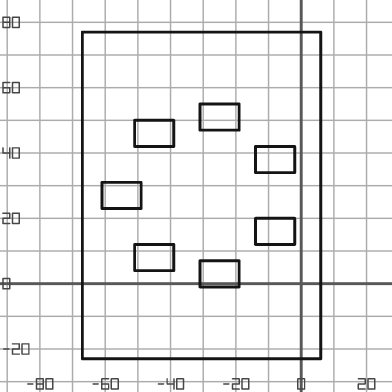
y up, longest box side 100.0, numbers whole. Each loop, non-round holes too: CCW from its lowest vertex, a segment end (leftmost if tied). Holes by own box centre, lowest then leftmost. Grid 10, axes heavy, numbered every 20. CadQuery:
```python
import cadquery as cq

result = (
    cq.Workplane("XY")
    .moveTo(-67.0, -23.0)
    .lineTo(6.0, -23.0)
    .lineTo(6.0, 77.0)
    .lineTo(-67.0, 77.0)
    .close()
    .moveTo(-31.0, -1.0)
    .lineTo(-19.0, -1.0)
    .lineTo(-19.0, 7.0)
    .lineTo(-31.0, 7.0)
    .close()
    .moveTo(-51.0, 4.0)
    .lineTo(-39.0, 4.0)
    .lineTo(-39.0, 12.0)
    .lineTo(-51.0, 12.0)
    .close()
    .moveTo(-14.0, 12.0)
    .lineTo(-2.0, 12.0)
    .lineTo(-2.0, 20.0)
    .lineTo(-14.0, 20.0)
    .close()
    .moveTo(-61.0, 23.0)
    .lineTo(-49.0, 23.0)
    .lineTo(-49.0, 31.0)
    .lineTo(-61.0, 31.0)
    .close()
    .moveTo(-14.0, 34.0)
    .lineTo(-2.0, 34.0)
    .lineTo(-2.0, 42.0)
    .lineTo(-14.0, 42.0)
    .close()
    .moveTo(-51.0, 42.0)
    .lineTo(-39.0, 42.0)
    .lineTo(-39.0, 50.0)
    .lineTo(-51.0, 50.0)
    .close()
    .moveTo(-31.0, 47.0)
    .lineTo(-19.0, 47.0)
    .lineTo(-19.0, 55.0)
    .lineTo(-31.0, 55.0)
    .close()
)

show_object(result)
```